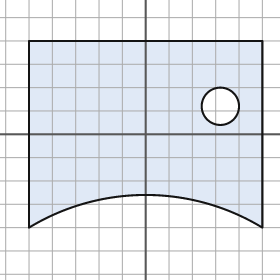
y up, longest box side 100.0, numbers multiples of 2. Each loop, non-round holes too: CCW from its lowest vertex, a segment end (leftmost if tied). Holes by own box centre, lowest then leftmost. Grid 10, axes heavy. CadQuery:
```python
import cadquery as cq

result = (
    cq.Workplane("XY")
    .moveTo(-50.0, -40.0)
    .threePointArc((0.0, -26.0), (50.0, -40.0))
    .lineTo(50.0, 40.0)
    .lineTo(-50.0, 40.0)
    .close()
    .moveTo(32.0, 12.0)
    .circle(8.0)
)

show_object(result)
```